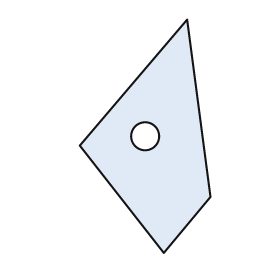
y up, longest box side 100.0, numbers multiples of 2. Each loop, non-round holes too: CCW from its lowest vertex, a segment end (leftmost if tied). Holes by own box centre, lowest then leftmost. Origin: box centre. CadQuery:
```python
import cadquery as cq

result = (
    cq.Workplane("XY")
    .moveTo(8.0, -50.0)
    .lineTo(28.0, -26.0)
    .lineTo(18.0, 50.0)
    .lineTo(-28.0, -4.0)
    .close()
    .moveTo(0.0, 0.0)
    .circle(6.0)
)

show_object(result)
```